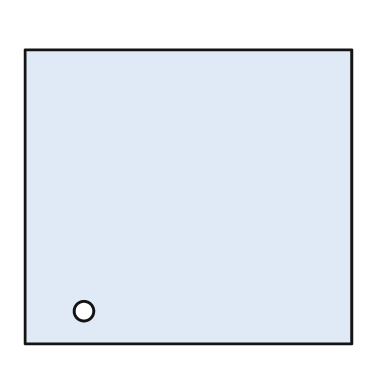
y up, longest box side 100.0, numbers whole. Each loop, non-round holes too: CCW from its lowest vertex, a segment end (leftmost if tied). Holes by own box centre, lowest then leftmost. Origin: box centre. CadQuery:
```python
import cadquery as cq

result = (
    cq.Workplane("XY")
    .moveTo(-50.0, -45.0)
    .lineTo(50.0, -45.0)
    .lineTo(50.0, 45.0)
    .lineTo(-50.0, 45.0)
    .close()
    .moveTo(-32.0, -35.0)
    .circle(3.0)
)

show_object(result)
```